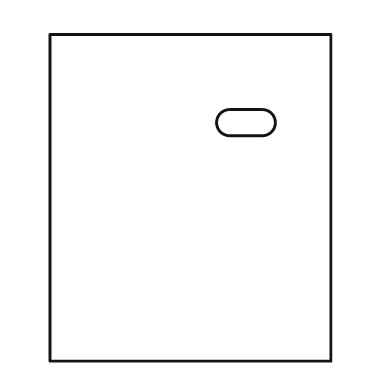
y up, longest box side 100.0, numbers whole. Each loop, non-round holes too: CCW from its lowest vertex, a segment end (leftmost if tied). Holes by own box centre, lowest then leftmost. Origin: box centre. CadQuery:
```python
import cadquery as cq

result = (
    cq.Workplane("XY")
    .moveTo(-43.0, -50.0)
    .lineTo(43.0, -50.0)
    .lineTo(43.0, 50.0)
    .lineTo(-43.0, 50.0)
    .close()
    .moveTo(12.0, 19.0)
    .lineTo(22.0, 19.0)
    .threePointArc((26.0, 23.0), (22.0, 27.0))
    .lineTo(12.0, 27.0)
    .threePointArc((8.0, 23.0), (12.0, 19.0))
    .close()
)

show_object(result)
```